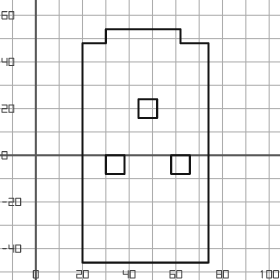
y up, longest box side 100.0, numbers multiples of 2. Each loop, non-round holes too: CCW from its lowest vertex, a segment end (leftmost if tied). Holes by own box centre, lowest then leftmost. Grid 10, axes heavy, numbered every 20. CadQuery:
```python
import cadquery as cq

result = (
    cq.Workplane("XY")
    .moveTo(20.0, -46.0)
    .lineTo(74.0, -46.0)
    .lineTo(74.0, 48.0)
    .lineTo(62.0, 48.0)
    .lineTo(62.0, 54.0)
    .lineTo(30.0, 54.0)
    .lineTo(30.0, 48.0)
    .lineTo(20.0, 48.0)
    .close()
    .moveTo(30.0, -8.0)
    .lineTo(38.0, -8.0)
    .lineTo(38.0, 0.0)
    .lineTo(30.0, 0.0)
    .close()
    .moveTo(58.0, -8.0)
    .lineTo(66.0, -8.0)
    .lineTo(66.0, 0.0)
    .lineTo(58.0, 0.0)
    .close()
    .moveTo(44.0, 16.0)
    .lineTo(52.0, 16.0)
    .lineTo(52.0, 24.0)
    .lineTo(44.0, 24.0)
    .close()
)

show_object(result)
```